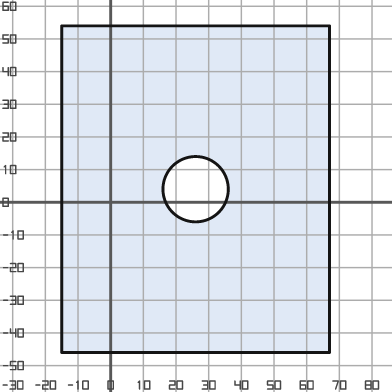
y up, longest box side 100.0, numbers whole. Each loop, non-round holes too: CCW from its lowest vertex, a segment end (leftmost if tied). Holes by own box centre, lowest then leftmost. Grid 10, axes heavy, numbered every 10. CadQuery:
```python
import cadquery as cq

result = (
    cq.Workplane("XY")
    .moveTo(-15.0, -46.0)
    .lineTo(67.0, -46.0)
    .lineTo(67.0, 54.0)
    .lineTo(-15.0, 54.0)
    .close()
    .moveTo(26.0, 4.0)
    .circle(10.0)
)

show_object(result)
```